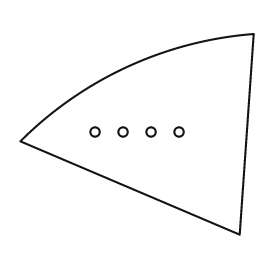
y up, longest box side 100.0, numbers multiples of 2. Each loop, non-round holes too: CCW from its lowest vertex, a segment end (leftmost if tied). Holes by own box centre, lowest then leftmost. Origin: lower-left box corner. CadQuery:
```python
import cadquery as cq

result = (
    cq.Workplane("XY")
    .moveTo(94.0, 0.0)
    .lineTo(100.0, 86.0)
    .threePointArc((46.0, 72.0), (0.0, 40.0))
    .close()
    .moveTo(32.0, 44.0)
    .circle(2.0)
    .moveTo(44.0, 44.0)
    .circle(2.0)
    .moveTo(56.0, 44.0)
    .circle(2.0)
    .moveTo(68.0, 44.0)
    .circle(2.0)
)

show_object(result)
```